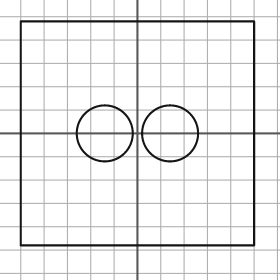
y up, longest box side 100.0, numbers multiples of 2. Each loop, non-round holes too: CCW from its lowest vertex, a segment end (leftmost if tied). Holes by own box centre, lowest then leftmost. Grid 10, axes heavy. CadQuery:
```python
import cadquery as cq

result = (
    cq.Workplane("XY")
    .moveTo(-50.0, -48.0)
    .lineTo(50.0, -48.0)
    .lineTo(50.0, 48.0)
    .lineTo(-50.0, 48.0)
    .close()
    .moveTo(-14.0, 0.0)
    .circle(12.0)
    .moveTo(14.0, 0.0)
    .circle(12.0)
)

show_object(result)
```